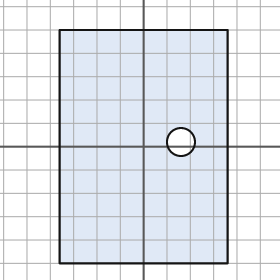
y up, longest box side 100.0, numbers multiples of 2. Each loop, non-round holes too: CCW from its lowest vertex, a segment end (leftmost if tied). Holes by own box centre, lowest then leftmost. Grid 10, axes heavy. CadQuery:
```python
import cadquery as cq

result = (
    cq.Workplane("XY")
    .moveTo(-36.0, -50.0)
    .lineTo(36.0, -50.0)
    .lineTo(36.0, 50.0)
    .lineTo(-36.0, 50.0)
    .close()
    .moveTo(16.0, 2.0)
    .circle(6.0)
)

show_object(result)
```